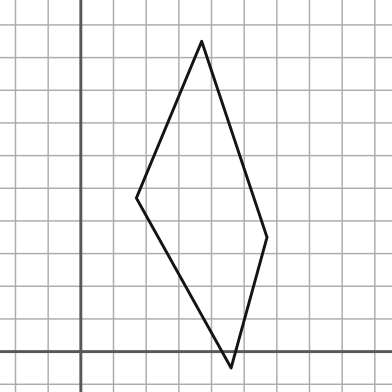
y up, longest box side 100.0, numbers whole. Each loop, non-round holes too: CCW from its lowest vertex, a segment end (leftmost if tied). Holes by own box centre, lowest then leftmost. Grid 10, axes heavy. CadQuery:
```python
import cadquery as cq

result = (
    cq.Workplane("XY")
    .moveTo(46.0, -5.0)
    .lineTo(57.0, 35.0)
    .lineTo(37.0, 95.0)
    .lineTo(17.0, 47.0)
    .close()
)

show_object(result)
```